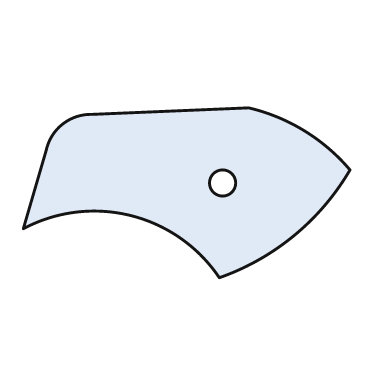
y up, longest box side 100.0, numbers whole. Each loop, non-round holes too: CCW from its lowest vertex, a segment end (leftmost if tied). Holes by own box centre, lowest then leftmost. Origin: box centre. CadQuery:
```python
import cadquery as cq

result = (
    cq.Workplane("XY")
    .moveTo(10.0, -26.0)
    .threePointArc((33.0, -13.0), (50.0, 7.0))
    .threePointArc((36.0, 19.0), (19.0, 26.0))
    .lineTo(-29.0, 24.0)
    .threePointArc((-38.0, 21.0), (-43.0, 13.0))
    .lineTo(-50.0, -11.0)
    .threePointArc((-17.0, -7.0), (10.0, -26.0))
    .close()
    .moveTo(11.0, 3.0)
    .circle(4.0)
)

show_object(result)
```